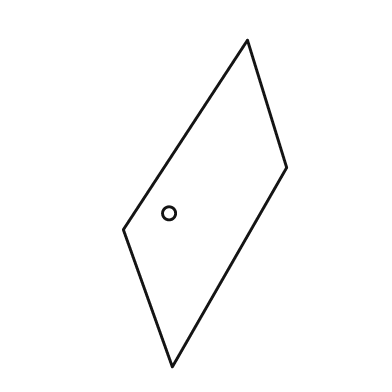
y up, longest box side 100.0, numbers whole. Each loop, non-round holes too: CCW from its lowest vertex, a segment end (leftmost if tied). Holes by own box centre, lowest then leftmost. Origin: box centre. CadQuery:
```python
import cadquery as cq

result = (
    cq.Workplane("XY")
    .moveTo(-10.0, -50.0)
    .lineTo(25.0, 11.0)
    .lineTo(13.0, 50.0)
    .lineTo(-25.0, -8.0)
    .close()
    .moveTo(-11.0, -3.0)
    .circle(2.0)
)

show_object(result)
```